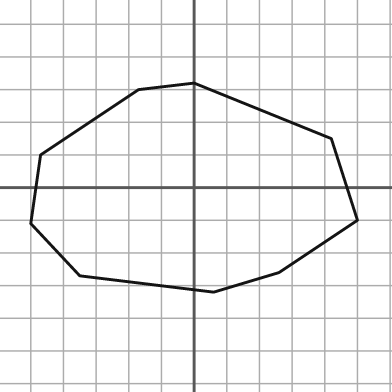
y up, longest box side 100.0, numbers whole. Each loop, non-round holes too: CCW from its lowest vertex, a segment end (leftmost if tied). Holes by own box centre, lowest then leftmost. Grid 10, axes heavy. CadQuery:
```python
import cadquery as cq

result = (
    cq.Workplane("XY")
    .moveTo(6.0, -32.0)
    .lineTo(26.0, -26.0)
    .lineTo(50.0, -10.0)
    .lineTo(42.0, 15.0)
    .lineTo(0.0, 32.0)
    .lineTo(-17.0, 30.0)
    .lineTo(-47.0, 10.0)
    .lineTo(-50.0, -11.0)
    .lineTo(-35.0, -27.0)
    .close()
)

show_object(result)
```